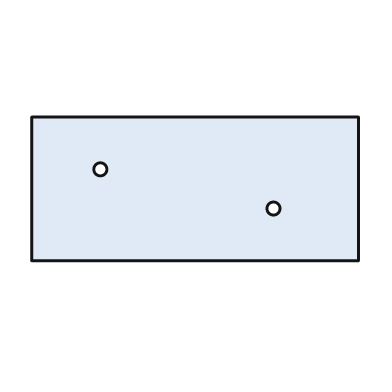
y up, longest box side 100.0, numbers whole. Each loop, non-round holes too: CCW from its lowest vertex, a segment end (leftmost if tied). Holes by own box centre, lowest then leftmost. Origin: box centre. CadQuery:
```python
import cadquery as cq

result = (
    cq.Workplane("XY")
    .moveTo(-50.0, -22.0)
    .lineTo(50.0, -22.0)
    .lineTo(50.0, 22.0)
    .lineTo(-50.0, 22.0)
    .close()
    .moveTo(24.0, -6.0)
    .circle(2.0)
    .moveTo(-29.0, 6.0)
    .circle(2.0)
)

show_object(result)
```